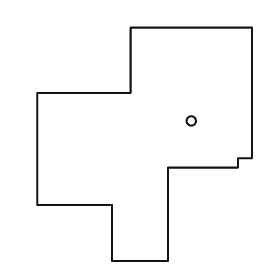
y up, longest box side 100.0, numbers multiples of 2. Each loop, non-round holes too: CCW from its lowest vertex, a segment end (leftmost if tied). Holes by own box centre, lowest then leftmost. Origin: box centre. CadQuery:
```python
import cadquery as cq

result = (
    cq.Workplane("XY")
    .moveTo(-14.0, -50.0)
    .lineTo(10.0, -50.0)
    .lineTo(10.0, -10.0)
    .lineTo(40.0, -10.0)
    .lineTo(40.0, -6.0)
    .lineTo(46.0, -6.0)
    .lineTo(46.0, 50.0)
    .lineTo(-6.0, 50.0)
    .lineTo(-6.0, 22.0)
    .lineTo(-46.0, 22.0)
    .lineTo(-46.0, -26.0)
    .lineTo(-14.0, -26.0)
    .close()
    .moveTo(20.0, 10.0)
    .circle(2.0)
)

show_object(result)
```